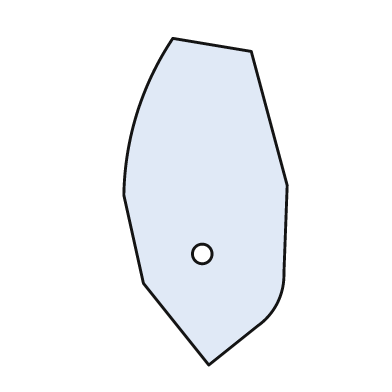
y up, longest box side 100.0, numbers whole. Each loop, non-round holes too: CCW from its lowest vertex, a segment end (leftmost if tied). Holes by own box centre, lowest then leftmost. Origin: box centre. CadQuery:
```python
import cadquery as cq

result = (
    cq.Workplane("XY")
    .moveTo(1.0, -50.0)
    .lineTo(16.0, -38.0)
    .threePointArc((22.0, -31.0), (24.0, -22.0))
    .lineTo(25.0, 5.0)
    .lineTo(14.0, 46.0)
    .lineTo(-10.0, 50.0)
    .threePointArc((-21.0, 27.0), (-25.0, 2.0))
    .lineTo(-19.0, -25.0)
    .close()
    .moveTo(-1.0, -16.0)
    .circle(3.0)
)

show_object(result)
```